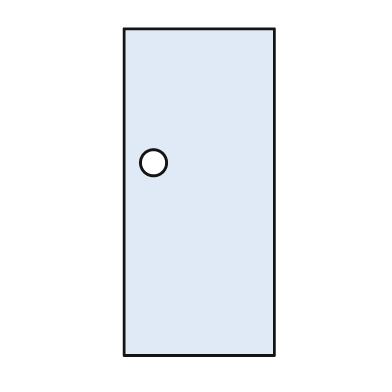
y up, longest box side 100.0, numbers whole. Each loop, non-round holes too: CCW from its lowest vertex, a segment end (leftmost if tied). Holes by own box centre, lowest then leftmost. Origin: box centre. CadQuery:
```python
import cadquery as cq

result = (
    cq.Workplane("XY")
    .moveTo(-23.0, -50.0)
    .lineTo(23.0, -50.0)
    .lineTo(23.0, 50.0)
    .lineTo(-23.0, 50.0)
    .close()
    .moveTo(-14.0, 9.0)
    .circle(4.0)
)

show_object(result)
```